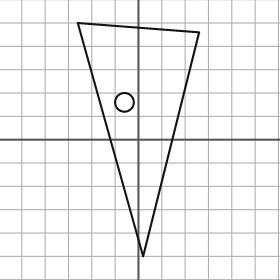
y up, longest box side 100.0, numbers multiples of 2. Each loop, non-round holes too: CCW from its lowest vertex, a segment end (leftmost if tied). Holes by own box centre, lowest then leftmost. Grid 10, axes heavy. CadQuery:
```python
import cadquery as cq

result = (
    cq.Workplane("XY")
    .moveTo(2.0, -50.0)
    .lineTo(26.0, 46.0)
    .lineTo(-26.0, 50.0)
    .close()
    .moveTo(-6.0, 16.0)
    .circle(4.0)
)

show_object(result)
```